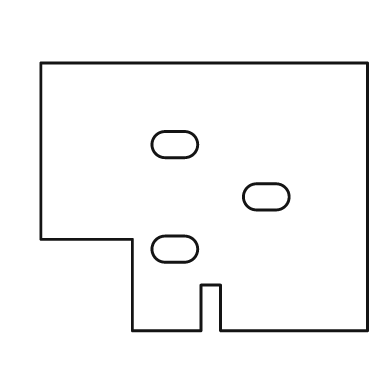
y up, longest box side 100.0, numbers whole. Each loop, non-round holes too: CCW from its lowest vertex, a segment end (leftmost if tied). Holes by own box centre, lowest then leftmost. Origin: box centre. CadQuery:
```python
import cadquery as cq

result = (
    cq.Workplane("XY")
    .moveTo(-22.0, -41.0)
    .lineTo(-1.0, -41.0)
    .lineTo(-1.0, -27.0)
    .lineTo(5.0, -27.0)
    .lineTo(5.0, -41.0)
    .lineTo(50.0, -41.0)
    .lineTo(50.0, 41.0)
    .lineTo(-50.0, 41.0)
    .lineTo(-50.0, -13.0)
    .lineTo(-22.0, -13.0)
    .close()
    .moveTo(-12.0, -20.0)
    .lineTo(-6.0, -20.0)
    .threePointArc((-2.0, -16.0), (-6.0, -12.0))
    .lineTo(-12.0, -12.0)
    .threePointArc((-16.0, -16.0), (-12.0, -20.0))
    .close()
    .moveTo(16.0, -4.0)
    .lineTo(22.0, -4.0)
    .threePointArc((26.0, 0.0), (22.0, 4.0))
    .lineTo(16.0, 4.0)
    .threePointArc((12.0, 0.0), (16.0, -4.0))
    .close()
    .moveTo(-12.0, 12.0)
    .lineTo(-6.0, 12.0)
    .threePointArc((-2.0, 16.0), (-6.0, 20.0))
    .lineTo(-12.0, 20.0)
    .threePointArc((-16.0, 16.0), (-12.0, 12.0))
    .close()
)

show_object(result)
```